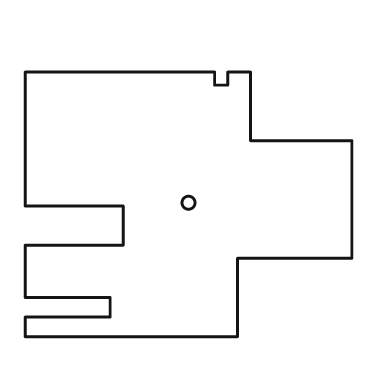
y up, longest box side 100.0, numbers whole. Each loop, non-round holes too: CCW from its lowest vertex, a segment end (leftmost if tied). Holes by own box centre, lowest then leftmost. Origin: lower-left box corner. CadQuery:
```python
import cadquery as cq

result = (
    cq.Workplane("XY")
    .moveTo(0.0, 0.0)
    .lineTo(65.0, 0.0)
    .lineTo(65.0, 24.0)
    .lineTo(100.0, 24.0)
    .lineTo(100.0, 60.0)
    .lineTo(69.0, 60.0)
    .lineTo(69.0, 81.0)
    .lineTo(62.0, 81.0)
    .lineTo(62.0, 77.0)
    .lineTo(58.0, 77.0)
    .lineTo(58.0, 81.0)
    .lineTo(0.0, 81.0)
    .lineTo(0.0, 40.0)
    .lineTo(30.0, 40.0)
    .lineTo(30.0, 28.0)
    .lineTo(0.0, 28.0)
    .lineTo(0.0, 12.0)
    .lineTo(26.0, 12.0)
    .lineTo(26.0, 6.0)
    .lineTo(0.0, 6.0)
    .close()
    .moveTo(50.0, 41.0)
    .circle(2.0)
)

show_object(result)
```